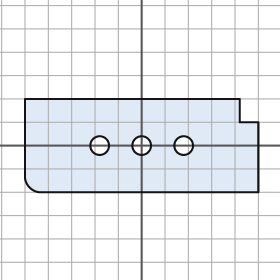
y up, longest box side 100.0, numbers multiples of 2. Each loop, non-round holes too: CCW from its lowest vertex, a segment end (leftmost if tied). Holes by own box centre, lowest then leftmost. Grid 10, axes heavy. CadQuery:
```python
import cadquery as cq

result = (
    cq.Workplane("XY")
    .moveTo(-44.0, -20.0)
    .lineTo(50.0, -20.0)
    .lineTo(50.0, 10.0)
    .lineTo(42.0, 10.0)
    .lineTo(42.0, 20.0)
    .lineTo(-50.0, 20.0)
    .lineTo(-50.0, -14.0)
    .threePointArc((-48.0, -18.0), (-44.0, -20.0))
    .close()
    .moveTo(-18.0, 0.0)
    .circle(4.0)
    .moveTo(0.0, 0.0)
    .circle(4.0)
    .moveTo(18.0, 0.0)
    .circle(4.0)
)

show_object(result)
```